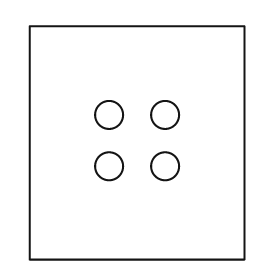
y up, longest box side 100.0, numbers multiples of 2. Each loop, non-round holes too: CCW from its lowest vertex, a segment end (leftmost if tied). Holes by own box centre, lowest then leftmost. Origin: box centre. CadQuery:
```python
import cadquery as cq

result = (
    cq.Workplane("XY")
    .moveTo(-46.0, -50.0)
    .lineTo(46.0, -50.0)
    .lineTo(46.0, 50.0)
    .lineTo(-46.0, 50.0)
    .close()
    .moveTo(-12.0, -10.0)
    .circle(6.0)
    .moveTo(12.0, -10.0)
    .circle(6.0)
    .moveTo(-12.0, 12.0)
    .circle(6.0)
    .moveTo(12.0, 12.0)
    .circle(6.0)
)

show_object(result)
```